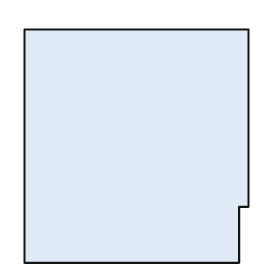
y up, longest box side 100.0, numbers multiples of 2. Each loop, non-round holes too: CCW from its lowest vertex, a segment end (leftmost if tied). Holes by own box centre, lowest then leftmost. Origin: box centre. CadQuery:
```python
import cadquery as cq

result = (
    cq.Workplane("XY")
    .moveTo(-48.0, -50.0)
    .lineTo(44.0, -50.0)
    .lineTo(44.0, -26.0)
    .lineTo(48.0, -26.0)
    .lineTo(48.0, 50.0)
    .lineTo(-48.0, 50.0)
    .close()
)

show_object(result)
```